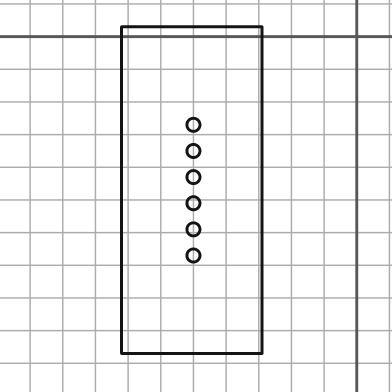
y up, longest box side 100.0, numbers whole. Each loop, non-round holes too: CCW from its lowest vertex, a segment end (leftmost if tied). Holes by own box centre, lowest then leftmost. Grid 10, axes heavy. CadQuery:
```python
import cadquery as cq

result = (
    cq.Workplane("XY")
    .moveTo(-72.0, -97.0)
    .lineTo(-29.0, -97.0)
    .lineTo(-29.0, 3.0)
    .lineTo(-72.0, 3.0)
    .close()
    .moveTo(-50.0, -67.0)
    .circle(2.0)
    .moveTo(-50.0, -59.0)
    .circle(2.0)
    .moveTo(-50.0, -51.0)
    .circle(2.0)
    .moveTo(-50.0, -43.0)
    .circle(2.0)
    .moveTo(-50.0, -35.0)
    .circle(2.0)
    .moveTo(-50.0, -27.0)
    .circle(2.0)
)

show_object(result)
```